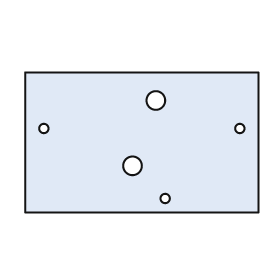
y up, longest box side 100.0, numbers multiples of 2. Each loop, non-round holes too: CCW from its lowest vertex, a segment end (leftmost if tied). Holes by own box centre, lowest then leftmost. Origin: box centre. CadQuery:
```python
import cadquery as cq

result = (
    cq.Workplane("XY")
    .moveTo(-50.0, -30.0)
    .lineTo(50.0, -30.0)
    .lineTo(50.0, 30.0)
    .lineTo(-50.0, 30.0)
    .close()
    .moveTo(10.0, -24.0)
    .circle(2.0)
    .moveTo(-4.0, -10.0)
    .circle(4.0)
    .moveTo(-42.0, 6.0)
    .circle(2.0)
    .moveTo(42.0, 6.0)
    .circle(2.0)
    .moveTo(6.0, 18.0)
    .circle(4.0)
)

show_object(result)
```